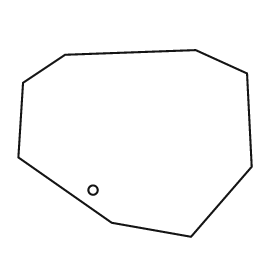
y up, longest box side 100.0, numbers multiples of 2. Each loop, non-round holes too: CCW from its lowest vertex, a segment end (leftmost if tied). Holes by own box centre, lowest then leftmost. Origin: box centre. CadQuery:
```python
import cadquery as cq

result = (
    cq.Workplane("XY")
    .moveTo(24.0, -40.0)
    .lineTo(50.0, -10.0)
    .lineTo(48.0, 30.0)
    .lineTo(26.0, 40.0)
    .lineTo(-30.0, 38.0)
    .lineTo(-48.0, 26.0)
    .lineTo(-50.0, -6.0)
    .lineTo(-10.0, -34.0)
    .close()
    .moveTo(-18.0, -20.0)
    .circle(2.0)
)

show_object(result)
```